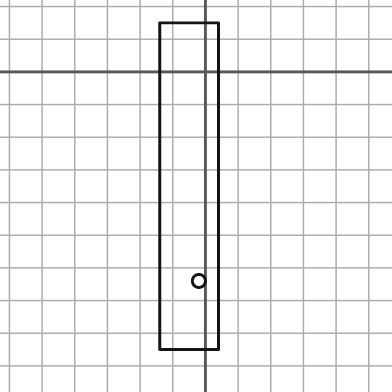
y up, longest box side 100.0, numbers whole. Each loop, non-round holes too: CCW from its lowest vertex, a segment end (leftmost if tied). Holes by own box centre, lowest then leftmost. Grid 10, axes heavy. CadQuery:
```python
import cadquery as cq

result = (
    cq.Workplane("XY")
    .moveTo(-14.0, -85.0)
    .lineTo(4.0, -85.0)
    .lineTo(4.0, 15.0)
    .lineTo(-14.0, 15.0)
    .close()
    .moveTo(-2.0, -64.0)
    .circle(2.0)
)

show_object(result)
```